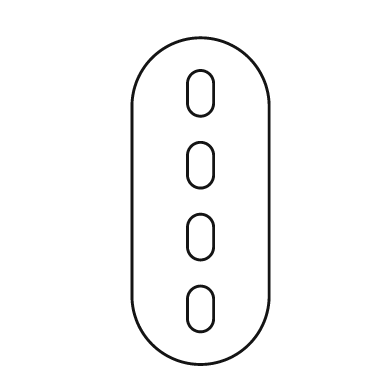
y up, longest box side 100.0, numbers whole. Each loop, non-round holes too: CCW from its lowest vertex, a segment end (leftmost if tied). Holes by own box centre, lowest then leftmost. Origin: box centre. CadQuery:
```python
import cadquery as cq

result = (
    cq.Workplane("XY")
    .moveTo(-21.0, -29.0)
    .threePointArc((0.0, -50.0), (21.0, -29.0))
    .lineTo(21.0, 29.0)
    .threePointArc((0.0, 50.0), (-21.0, 29.0))
    .close()
    .moveTo(-4.0, -36.0)
    .threePointArc((0.0, -40.0), (4.0, -36.0))
    .lineTo(4.0, -30.0)
    .threePointArc((0.0, -26.0), (-4.0, -30.0))
    .close()
    .moveTo(-4.0, -14.0)
    .threePointArc((0.0, -18.0), (4.0, -14.0))
    .lineTo(4.0, -8.0)
    .threePointArc((0.0, -4.0), (-4.0, -8.0))
    .close()
    .moveTo(-4.0, 8.0)
    .threePointArc((0.0, 4.0), (4.0, 8.0))
    .lineTo(4.0, 14.0)
    .threePointArc((0.0, 18.0), (-4.0, 14.0))
    .close()
    .moveTo(-4.0, 30.0)
    .threePointArc((0.0, 26.0), (4.0, 30.0))
    .lineTo(4.0, 36.0)
    .threePointArc((0.0, 40.0), (-4.0, 36.0))
    .close()
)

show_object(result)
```